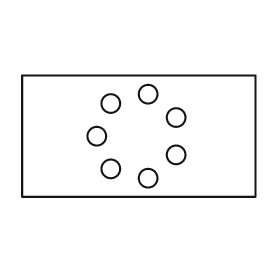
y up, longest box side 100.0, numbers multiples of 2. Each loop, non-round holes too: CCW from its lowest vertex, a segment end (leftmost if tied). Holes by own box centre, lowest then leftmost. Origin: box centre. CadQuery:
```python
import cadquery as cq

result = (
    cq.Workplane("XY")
    .moveTo(-50.0, -26.0)
    .lineTo(50.0, -26.0)
    .lineTo(50.0, 26.0)
    .lineTo(-50.0, 26.0)
    .close()
    .moveTo(4.0, -18.0)
    .circle(4.0)
    .moveTo(-12.0, -14.0)
    .circle(4.0)
    .moveTo(16.0, -8.0)
    .circle(4.0)
    .moveTo(-18.0, 0.0)
    .circle(4.0)
    .moveTo(16.0, 8.0)
    .circle(4.0)
    .moveTo(-12.0, 14.0)
    .circle(4.0)
    .moveTo(4.0, 18.0)
    .circle(4.0)
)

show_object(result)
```